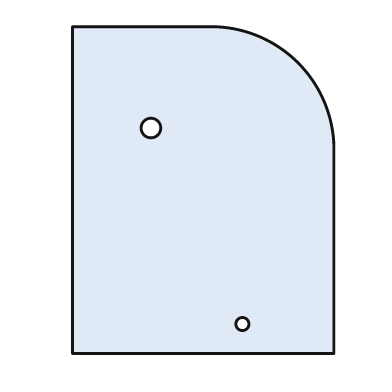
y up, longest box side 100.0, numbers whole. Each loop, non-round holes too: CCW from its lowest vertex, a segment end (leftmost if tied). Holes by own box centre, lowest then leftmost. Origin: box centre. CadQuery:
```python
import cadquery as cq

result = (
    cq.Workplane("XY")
    .moveTo(-40.0, -50.0)
    .lineTo(40.0, -50.0)
    .lineTo(40.0, 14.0)
    .threePointArc((29.0, 39.0), (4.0, 50.0))
    .lineTo(-40.0, 50.0)
    .close()
    .moveTo(12.0, -41.0)
    .circle(2.0)
    .moveTo(-16.0, 19.0)
    .circle(3.0)
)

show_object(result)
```